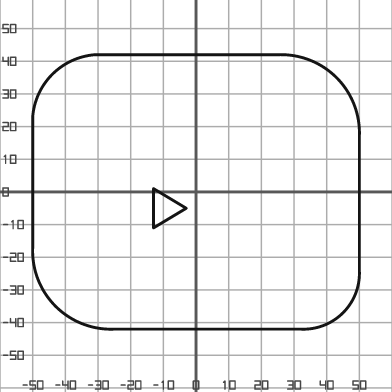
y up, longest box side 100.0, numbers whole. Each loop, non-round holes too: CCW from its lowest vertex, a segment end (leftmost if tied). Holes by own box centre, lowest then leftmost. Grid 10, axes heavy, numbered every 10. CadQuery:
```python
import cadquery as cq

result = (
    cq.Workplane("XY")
    .moveTo(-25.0, -42.0)
    .lineTo(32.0, -42.0)
    .threePointArc((45.0, -37.0), (50.0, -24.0))
    .lineTo(50.0, 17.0)
    .threePointArc((43.0, 35.0), (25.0, 42.0))
    .lineTo(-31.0, 42.0)
    .threePointArc((-44.0, 36.0), (-50.0, 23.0))
    .lineTo(-50.0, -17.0)
    .threePointArc((-43.0, -35.0), (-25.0, -42.0))
    .close()
    .moveTo(-13.0, -11.0)
    .lineTo(-3.0, -5.0)
    .lineTo(-13.0, 1.0)
    .close()
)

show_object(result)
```